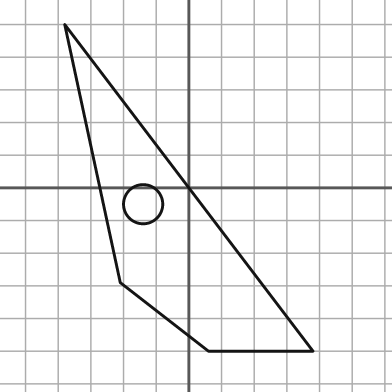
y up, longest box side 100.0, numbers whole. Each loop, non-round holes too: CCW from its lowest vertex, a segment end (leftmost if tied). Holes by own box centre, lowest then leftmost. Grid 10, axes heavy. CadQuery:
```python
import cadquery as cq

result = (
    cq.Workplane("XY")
    .moveTo(6.0, -50.0)
    .lineTo(38.0, -50.0)
    .lineTo(-38.0, 50.0)
    .lineTo(-21.0, -29.0)
    .close()
    .moveTo(-14.0, -5.0)
    .circle(6.0)
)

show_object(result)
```